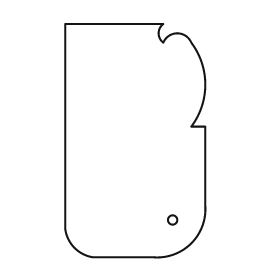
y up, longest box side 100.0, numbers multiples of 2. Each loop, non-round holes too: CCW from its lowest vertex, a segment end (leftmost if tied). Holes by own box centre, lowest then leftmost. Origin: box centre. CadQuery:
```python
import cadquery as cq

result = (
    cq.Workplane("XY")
    .moveTo(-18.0, -50.0)
    .lineTo(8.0, -50.0)
    .threePointArc((24.0, -44.0), (30.0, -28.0))
    .lineTo(30.0, 6.0)
    .lineTo(24.0, 6.0)
    .threePointArc((30.0, 24.0), (24.0, 42.0))
    .threePointArc((18.0, 46.0), (12.0, 42.0))
    .threePointArc((10.0, 46.0), (12.0, 50.0))
    .lineTo(-30.0, 50.0)
    .lineTo(-30.0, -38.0)
    .threePointArc((-26.0, -46.0), (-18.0, -50.0))
    .close()
    .moveTo(16.0, -34.0)
    .circle(2.0)
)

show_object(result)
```